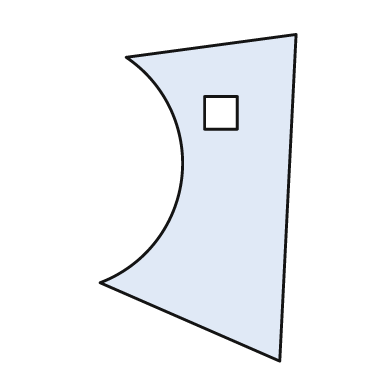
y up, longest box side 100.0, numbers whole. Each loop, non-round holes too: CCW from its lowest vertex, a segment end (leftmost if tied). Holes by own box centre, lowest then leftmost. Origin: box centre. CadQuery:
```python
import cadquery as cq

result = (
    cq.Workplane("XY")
    .moveTo(25.0, -50.0)
    .lineTo(30.0, 50.0)
    .lineTo(-22.0, 43.0)
    .threePointArc((-5.0, 6.0), (-30.0, -26.0))
    .close()
    .moveTo(2.0, 21.0)
    .lineTo(12.0, 21.0)
    .lineTo(12.0, 31.0)
    .lineTo(2.0, 31.0)
    .close()
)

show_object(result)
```